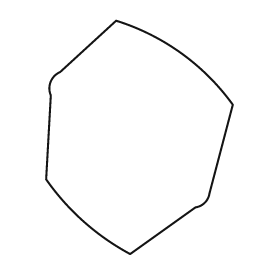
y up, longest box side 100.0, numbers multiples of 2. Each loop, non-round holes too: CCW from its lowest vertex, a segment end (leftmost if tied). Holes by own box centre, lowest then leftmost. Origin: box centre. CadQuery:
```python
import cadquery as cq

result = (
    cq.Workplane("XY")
    .moveTo(-4.0, -50.0)
    .lineTo(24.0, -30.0)
    .threePointArc((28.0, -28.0), (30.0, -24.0))
    .lineTo(40.0, 14.0)
    .threePointArc((18.0, 36.0), (-10.0, 50.0))
    .lineTo(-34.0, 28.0)
    .threePointArc((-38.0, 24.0), (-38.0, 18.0))
    .lineTo(-40.0, -18.0)
    .threePointArc((-24.0, -36.0), (-4.0, -50.0))
    .close()
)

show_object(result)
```